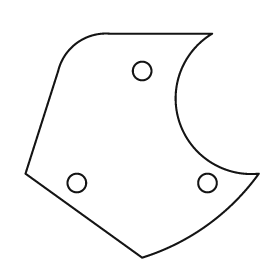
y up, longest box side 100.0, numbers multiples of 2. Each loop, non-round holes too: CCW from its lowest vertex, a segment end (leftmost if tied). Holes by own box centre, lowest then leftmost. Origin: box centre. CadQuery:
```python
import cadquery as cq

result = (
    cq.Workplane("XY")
    .moveTo(0.0, -48.0)
    .threePointArc((28.0, -34.0), (50.0, -12.0))
    .threePointArc((16.0, 10.0), (30.0, 48.0))
    .lineTo(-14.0, 48.0)
    .threePointArc((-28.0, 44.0), (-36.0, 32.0))
    .lineTo(-50.0, -12.0)
    .close()
    .moveTo(-28.0, -16.0)
    .circle(4.0)
    .moveTo(28.0, -16.0)
    .circle(4.0)
    .moveTo(0.0, 32.0)
    .circle(4.0)
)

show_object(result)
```